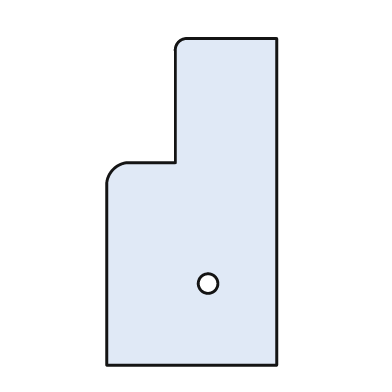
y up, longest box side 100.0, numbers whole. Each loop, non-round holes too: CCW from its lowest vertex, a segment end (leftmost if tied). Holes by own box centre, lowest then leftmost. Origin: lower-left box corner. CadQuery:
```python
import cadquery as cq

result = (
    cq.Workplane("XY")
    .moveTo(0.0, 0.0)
    .lineTo(52.0, 0.0)
    .lineTo(52.0, 100.0)
    .lineTo(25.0, 100.0)
    .threePointArc((22.0, 99.0), (21.0, 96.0))
    .lineTo(21.0, 62.0)
    .lineTo(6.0, 62.0)
    .threePointArc((2.0, 60.0), (0.0, 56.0))
    .close()
    .moveTo(31.0, 25.0)
    .circle(3.0)
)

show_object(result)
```